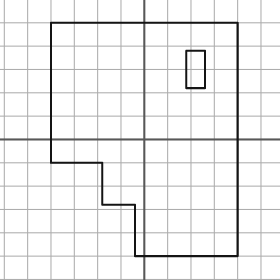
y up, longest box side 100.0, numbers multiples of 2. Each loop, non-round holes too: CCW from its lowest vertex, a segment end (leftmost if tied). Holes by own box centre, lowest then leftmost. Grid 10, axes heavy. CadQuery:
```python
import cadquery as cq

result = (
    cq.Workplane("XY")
    .moveTo(-4.0, -50.0)
    .lineTo(40.0, -50.0)
    .lineTo(40.0, 50.0)
    .lineTo(-40.0, 50.0)
    .lineTo(-40.0, -10.0)
    .lineTo(-18.0, -10.0)
    .lineTo(-18.0, -28.0)
    .lineTo(-4.0, -28.0)
    .close()
    .moveTo(18.0, 22.0)
    .lineTo(26.0, 22.0)
    .lineTo(26.0, 38.0)
    .lineTo(18.0, 38.0)
    .close()
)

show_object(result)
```